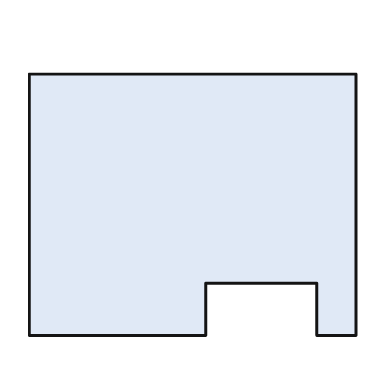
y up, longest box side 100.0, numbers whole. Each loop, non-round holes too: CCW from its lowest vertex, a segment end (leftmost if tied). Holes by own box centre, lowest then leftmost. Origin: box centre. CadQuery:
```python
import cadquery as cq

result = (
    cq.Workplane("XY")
    .moveTo(-50.0, -40.0)
    .lineTo(4.0, -40.0)
    .lineTo(4.0, -24.0)
    .lineTo(38.0, -24.0)
    .lineTo(38.0, -40.0)
    .lineTo(50.0, -40.0)
    .lineTo(50.0, 40.0)
    .lineTo(-50.0, 40.0)
    .close()
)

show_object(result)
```